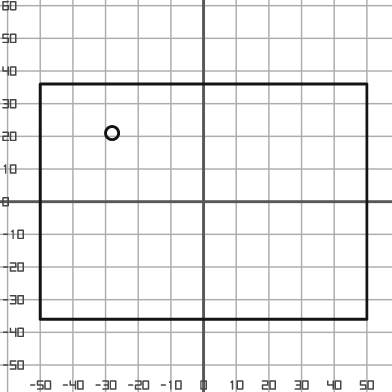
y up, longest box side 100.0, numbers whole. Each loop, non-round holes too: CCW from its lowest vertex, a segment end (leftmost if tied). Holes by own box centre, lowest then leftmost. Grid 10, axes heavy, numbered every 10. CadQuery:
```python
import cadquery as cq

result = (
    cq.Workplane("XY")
    .moveTo(-50.0, -36.0)
    .lineTo(50.0, -36.0)
    .lineTo(50.0, 36.0)
    .lineTo(-50.0, 36.0)
    .close()
    .moveTo(-28.0, 21.0)
    .circle(2.0)
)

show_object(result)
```